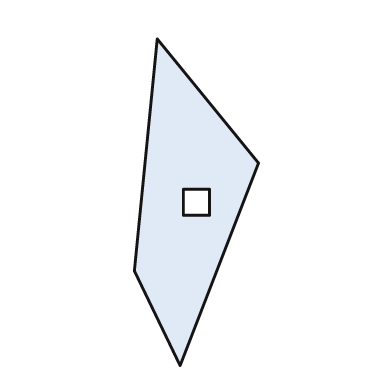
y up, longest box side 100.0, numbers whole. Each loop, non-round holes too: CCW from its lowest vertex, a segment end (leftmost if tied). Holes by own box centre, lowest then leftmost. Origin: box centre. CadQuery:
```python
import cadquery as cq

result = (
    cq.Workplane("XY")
    .moveTo(-5.0, -50.0)
    .lineTo(19.0, 12.0)
    .lineTo(-12.0, 50.0)
    .lineTo(-19.0, -21.0)
    .close()
    .moveTo(-4.0, -4.0)
    .lineTo(4.0, -4.0)
    .lineTo(4.0, 4.0)
    .lineTo(-4.0, 4.0)
    .close()
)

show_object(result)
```